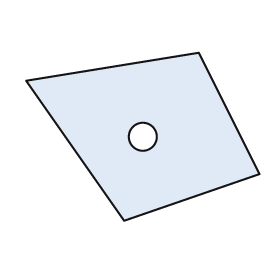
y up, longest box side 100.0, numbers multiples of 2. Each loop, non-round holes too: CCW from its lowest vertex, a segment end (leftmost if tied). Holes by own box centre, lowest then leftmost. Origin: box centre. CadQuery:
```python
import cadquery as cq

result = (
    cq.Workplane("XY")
    .moveTo(-8.0, -36.0)
    .lineTo(50.0, -16.0)
    .lineTo(24.0, 36.0)
    .lineTo(-50.0, 24.0)
    .close()
    .moveTo(0.0, 0.0)
    .circle(6.0)
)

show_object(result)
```